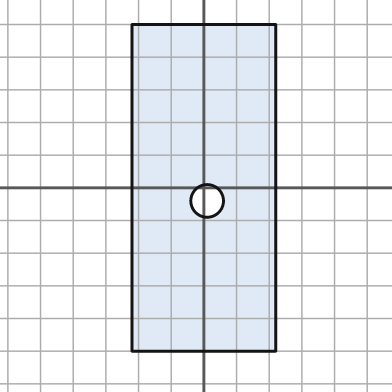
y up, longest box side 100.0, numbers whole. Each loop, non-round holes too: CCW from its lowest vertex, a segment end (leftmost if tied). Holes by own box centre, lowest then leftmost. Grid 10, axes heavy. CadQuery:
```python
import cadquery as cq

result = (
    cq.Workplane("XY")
    .moveTo(-22.0, -50.0)
    .lineTo(22.0, -50.0)
    .lineTo(22.0, 50.0)
    .lineTo(-22.0, 50.0)
    .close()
    .moveTo(1.0, -4.0)
    .circle(5.0)
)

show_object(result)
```